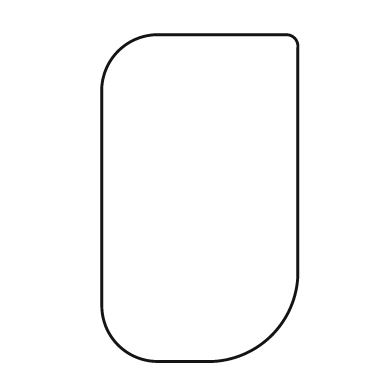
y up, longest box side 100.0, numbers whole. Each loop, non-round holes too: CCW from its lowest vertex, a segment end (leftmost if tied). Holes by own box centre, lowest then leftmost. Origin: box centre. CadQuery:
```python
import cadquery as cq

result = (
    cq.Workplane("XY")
    .moveTo(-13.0, -50.0)
    .lineTo(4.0, -50.0)
    .threePointArc((22.0, -42.0), (30.0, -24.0))
    .lineTo(30.0, 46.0)
    .threePointArc((29.0, 49.0), (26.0, 50.0))
    .lineTo(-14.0, 50.0)
    .threePointArc((-25.0, 45.0), (-30.0, 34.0))
    .lineTo(-30.0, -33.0)
    .threePointArc((-25.0, -45.0), (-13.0, -50.0))
    .close()
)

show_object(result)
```